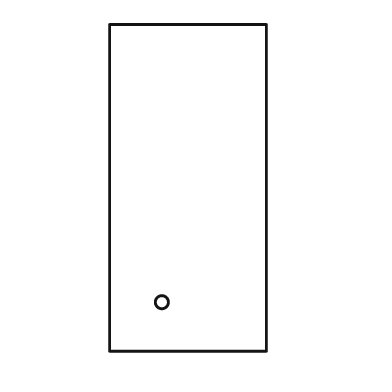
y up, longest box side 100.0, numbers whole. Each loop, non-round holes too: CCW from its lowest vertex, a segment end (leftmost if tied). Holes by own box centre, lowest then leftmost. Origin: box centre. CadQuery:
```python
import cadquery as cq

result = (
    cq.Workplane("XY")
    .moveTo(-24.0, -50.0)
    .lineTo(24.0, -50.0)
    .lineTo(24.0, 50.0)
    .lineTo(-24.0, 50.0)
    .close()
    .moveTo(-8.0, -35.0)
    .circle(2.0)
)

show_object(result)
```